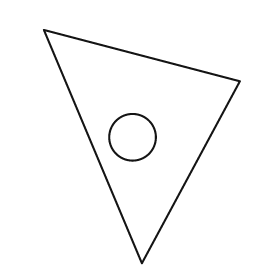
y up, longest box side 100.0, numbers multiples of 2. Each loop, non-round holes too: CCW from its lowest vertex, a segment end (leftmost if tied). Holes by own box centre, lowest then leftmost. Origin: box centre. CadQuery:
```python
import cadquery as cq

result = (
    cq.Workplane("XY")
    .moveTo(0.0, -50.0)
    .lineTo(42.0, 28.0)
    .lineTo(-42.0, 50.0)
    .close()
    .moveTo(-4.0, 4.0)
    .circle(10.0)
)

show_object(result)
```